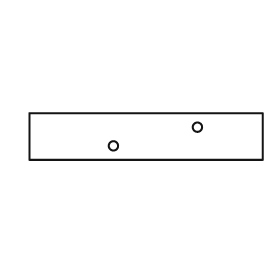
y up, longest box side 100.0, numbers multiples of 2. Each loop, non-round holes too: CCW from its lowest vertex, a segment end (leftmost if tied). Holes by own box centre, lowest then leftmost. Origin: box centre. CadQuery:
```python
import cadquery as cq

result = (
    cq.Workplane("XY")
    .moveTo(-50.0, -10.0)
    .lineTo(50.0, -10.0)
    .lineTo(50.0, 10.0)
    .lineTo(-50.0, 10.0)
    .close()
    .moveTo(-14.0, -4.0)
    .circle(2.0)
    .moveTo(22.0, 4.0)
    .circle(2.0)
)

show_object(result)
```